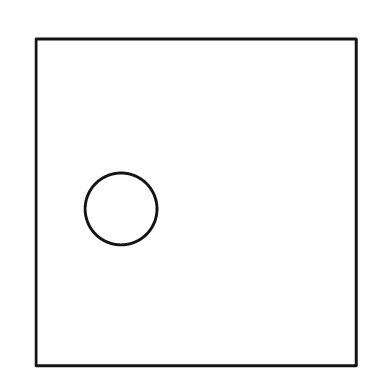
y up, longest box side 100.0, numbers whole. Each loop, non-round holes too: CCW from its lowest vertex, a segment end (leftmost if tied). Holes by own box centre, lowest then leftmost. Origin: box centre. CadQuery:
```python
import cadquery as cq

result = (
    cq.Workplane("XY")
    .moveTo(-49.0, -50.0)
    .lineTo(49.0, -50.0)
    .lineTo(49.0, 50.0)
    .lineTo(-49.0, 50.0)
    .close()
    .moveTo(-23.0, -2.0)
    .circle(11.0)
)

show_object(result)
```